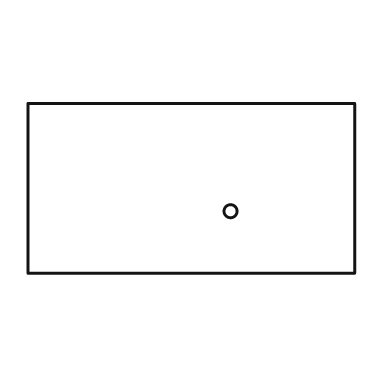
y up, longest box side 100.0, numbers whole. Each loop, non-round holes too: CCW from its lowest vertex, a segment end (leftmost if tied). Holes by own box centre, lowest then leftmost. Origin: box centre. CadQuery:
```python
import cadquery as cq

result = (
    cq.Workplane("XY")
    .moveTo(-50.0, -26.0)
    .lineTo(50.0, -26.0)
    .lineTo(50.0, 26.0)
    .lineTo(-50.0, 26.0)
    .close()
    .moveTo(12.0, -7.0)
    .circle(2.0)
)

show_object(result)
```